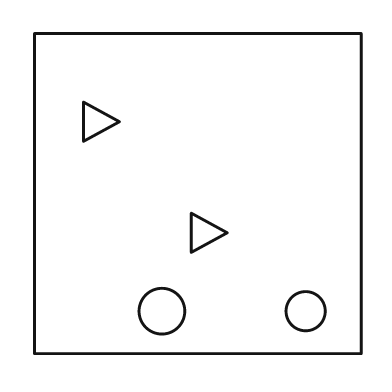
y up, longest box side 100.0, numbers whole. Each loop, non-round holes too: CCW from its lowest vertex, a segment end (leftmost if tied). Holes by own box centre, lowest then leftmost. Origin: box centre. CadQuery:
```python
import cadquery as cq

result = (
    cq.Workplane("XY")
    .moveTo(-50.0, -49.0)
    .lineTo(50.0, -49.0)
    .lineTo(50.0, 49.0)
    .lineTo(-50.0, 49.0)
    .close()
    .moveTo(-11.0, -36.0)
    .circle(7.0)
    .moveTo(33.0, -36.0)
    .circle(6.0)
    .moveTo(-2.0, -18.0)
    .lineTo(9.0, -12.0)
    .lineTo(-2.0, -6.0)
    .close()
    .moveTo(-35.0, 16.0)
    .lineTo(-24.0, 22.0)
    .lineTo(-35.0, 28.0)
    .close()
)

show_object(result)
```